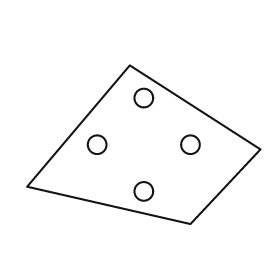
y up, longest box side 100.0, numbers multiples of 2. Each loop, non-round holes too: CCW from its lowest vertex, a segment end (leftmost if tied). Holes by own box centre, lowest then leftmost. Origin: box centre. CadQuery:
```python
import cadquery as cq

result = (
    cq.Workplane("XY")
    .moveTo(20.0, -34.0)
    .lineTo(50.0, -2.0)
    .lineTo(-6.0, 34.0)
    .lineTo(-50.0, -18.0)
    .close()
    .moveTo(0.0, -20.0)
    .circle(4.0)
    .moveTo(-20.0, 0.0)
    .circle(4.0)
    .moveTo(20.0, 0.0)
    .circle(4.0)
    .moveTo(0.0, 20.0)
    .circle(4.0)
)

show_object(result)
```